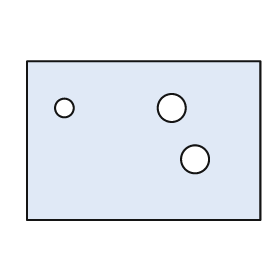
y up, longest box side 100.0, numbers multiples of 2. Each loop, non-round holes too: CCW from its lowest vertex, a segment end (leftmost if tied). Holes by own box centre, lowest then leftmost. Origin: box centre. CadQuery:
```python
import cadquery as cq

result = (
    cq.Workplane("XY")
    .moveTo(-50.0, -34.0)
    .lineTo(50.0, -34.0)
    .lineTo(50.0, 34.0)
    .lineTo(-50.0, 34.0)
    .close()
    .moveTo(22.0, -8.0)
    .circle(6.0)
    .moveTo(-34.0, 14.0)
    .circle(4.0)
    .moveTo(12.0, 14.0)
    .circle(6.0)
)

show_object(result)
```